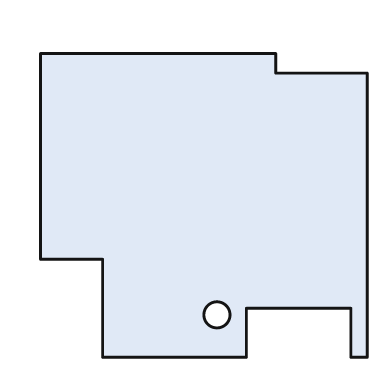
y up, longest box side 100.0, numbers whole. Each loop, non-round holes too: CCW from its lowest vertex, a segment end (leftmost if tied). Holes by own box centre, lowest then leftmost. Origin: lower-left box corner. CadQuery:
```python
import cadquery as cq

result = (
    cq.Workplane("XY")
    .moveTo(19.0, 0.0)
    .lineTo(63.0, 0.0)
    .lineTo(63.0, 15.0)
    .lineTo(95.0, 15.0)
    .lineTo(95.0, 0.0)
    .lineTo(100.0, 0.0)
    .lineTo(100.0, 87.0)
    .lineTo(72.0, 87.0)
    .lineTo(72.0, 93.0)
    .lineTo(0.0, 93.0)
    .lineTo(0.0, 30.0)
    .lineTo(19.0, 30.0)
    .close()
    .moveTo(54.0, 13.0)
    .circle(4.0)
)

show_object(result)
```